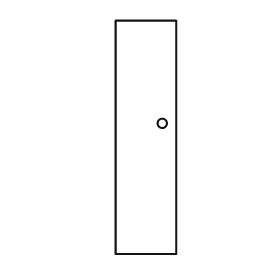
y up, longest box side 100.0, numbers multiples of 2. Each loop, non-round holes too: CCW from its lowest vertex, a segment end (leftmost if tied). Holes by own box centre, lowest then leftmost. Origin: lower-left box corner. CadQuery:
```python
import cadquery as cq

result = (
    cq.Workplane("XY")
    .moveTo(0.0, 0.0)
    .lineTo(26.0, 0.0)
    .lineTo(26.0, 100.0)
    .lineTo(0.0, 100.0)
    .close()
    .moveTo(20.0, 56.0)
    .circle(2.0)
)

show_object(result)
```